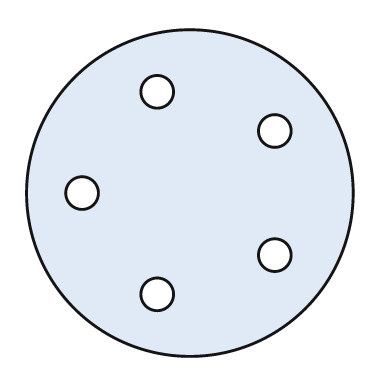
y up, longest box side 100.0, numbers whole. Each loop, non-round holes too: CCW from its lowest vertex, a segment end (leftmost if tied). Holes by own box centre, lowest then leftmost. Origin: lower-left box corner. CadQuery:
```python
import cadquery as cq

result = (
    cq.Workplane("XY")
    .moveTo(50.0, 50.0)
    .circle(50.0)
    .moveTo(40.0, 19.0)
    .circle(5.0)
    .moveTo(76.0, 31.0)
    .circle(5.0)
    .moveTo(17.0, 50.0)
    .circle(5.0)
    .moveTo(76.0, 69.0)
    .circle(5.0)
    .moveTo(40.0, 81.0)
    .circle(5.0)
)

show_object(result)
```